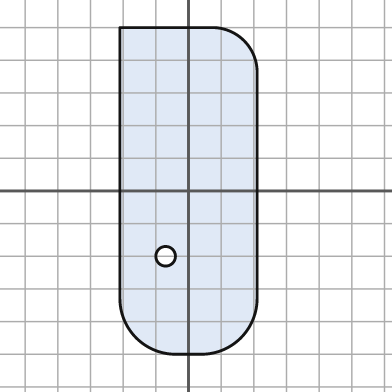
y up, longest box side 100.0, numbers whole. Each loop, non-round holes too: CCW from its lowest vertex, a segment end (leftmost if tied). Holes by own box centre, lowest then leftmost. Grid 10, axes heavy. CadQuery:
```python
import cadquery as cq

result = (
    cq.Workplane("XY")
    .moveTo(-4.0, -50.0)
    .lineTo(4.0, -50.0)
    .threePointArc((16.0, -45.0), (21.0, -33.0))
    .lineTo(21.0, 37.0)
    .threePointArc((17.0, 46.0), (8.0, 50.0))
    .lineTo(-21.0, 50.0)
    .lineTo(-21.0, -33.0)
    .threePointArc((-16.0, -45.0), (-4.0, -50.0))
    .close()
    .moveTo(-7.0, -20.0)
    .circle(3.0)
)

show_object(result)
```